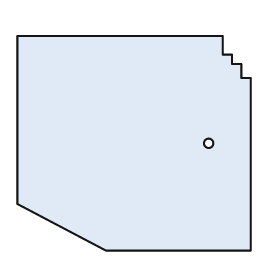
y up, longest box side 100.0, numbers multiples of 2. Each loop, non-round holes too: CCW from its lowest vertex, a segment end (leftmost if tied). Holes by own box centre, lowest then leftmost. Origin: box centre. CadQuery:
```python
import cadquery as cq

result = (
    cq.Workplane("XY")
    .moveTo(-12.0, -46.0)
    .lineTo(50.0, -46.0)
    .lineTo(50.0, 28.0)
    .lineTo(46.0, 28.0)
    .lineTo(46.0, 34.0)
    .lineTo(42.0, 34.0)
    .lineTo(42.0, 38.0)
    .lineTo(38.0, 38.0)
    .lineTo(38.0, 46.0)
    .lineTo(-50.0, 46.0)
    .lineTo(-50.0, -26.0)
    .close()
    .moveTo(32.0, 0.0)
    .circle(2.0)
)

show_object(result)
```